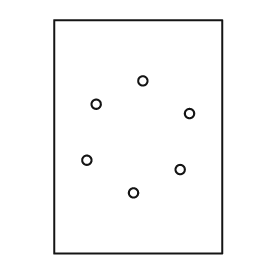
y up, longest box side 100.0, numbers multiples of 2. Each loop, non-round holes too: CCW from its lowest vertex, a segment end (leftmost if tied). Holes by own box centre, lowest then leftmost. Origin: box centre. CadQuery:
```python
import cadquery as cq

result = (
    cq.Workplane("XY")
    .moveTo(-36.0, -50.0)
    .lineTo(36.0, -50.0)
    .lineTo(36.0, 50.0)
    .lineTo(-36.0, 50.0)
    .close()
    .moveTo(-2.0, -24.0)
    .circle(2.0)
    .moveTo(18.0, -14.0)
    .circle(2.0)
    .moveTo(-22.0, -10.0)
    .circle(2.0)
    .moveTo(22.0, 10.0)
    .circle(2.0)
    .moveTo(-18.0, 14.0)
    .circle(2.0)
    .moveTo(2.0, 24.0)
    .circle(2.0)
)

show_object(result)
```